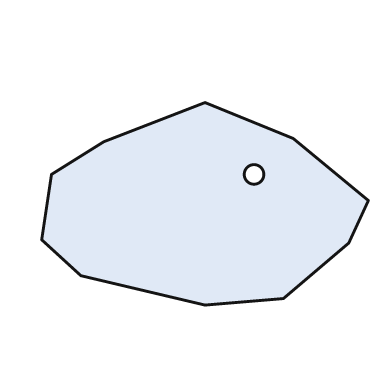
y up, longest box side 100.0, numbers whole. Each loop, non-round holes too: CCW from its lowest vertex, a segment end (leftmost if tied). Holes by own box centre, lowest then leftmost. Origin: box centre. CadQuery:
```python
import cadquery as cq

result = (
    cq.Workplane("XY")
    .moveTo(0.0, -31.0)
    .lineTo(24.0, -29.0)
    .lineTo(44.0, -12.0)
    .lineTo(50.0, 1.0)
    .lineTo(27.0, 20.0)
    .lineTo(0.0, 31.0)
    .lineTo(-31.0, 19.0)
    .lineTo(-47.0, 9.0)
    .lineTo(-50.0, -11.0)
    .lineTo(-38.0, -22.0)
    .close()
    .moveTo(15.0, 9.0)
    .circle(3.0)
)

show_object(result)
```